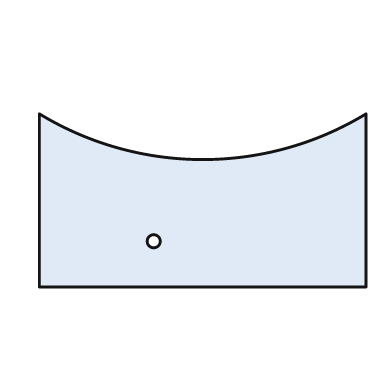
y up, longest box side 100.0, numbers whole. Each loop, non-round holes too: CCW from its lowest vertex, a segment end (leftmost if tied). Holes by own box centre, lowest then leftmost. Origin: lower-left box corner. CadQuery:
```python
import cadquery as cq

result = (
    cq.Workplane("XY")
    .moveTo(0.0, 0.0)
    .lineTo(100.0, 0.0)
    .lineTo(100.0, 53.0)
    .threePointArc((50.0, 39.0), (0.0, 53.0))
    .close()
    .moveTo(35.0, 14.0)
    .circle(2.0)
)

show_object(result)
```